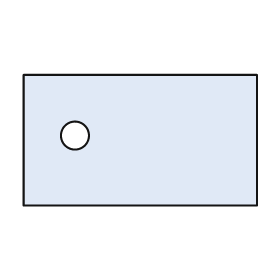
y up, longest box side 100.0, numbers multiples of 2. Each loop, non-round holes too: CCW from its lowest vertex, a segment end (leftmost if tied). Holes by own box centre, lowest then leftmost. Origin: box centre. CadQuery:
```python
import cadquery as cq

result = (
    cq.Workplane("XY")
    .moveTo(-50.0, -28.0)
    .lineTo(50.0, -28.0)
    .lineTo(50.0, 28.0)
    .lineTo(-50.0, 28.0)
    .close()
    .moveTo(-28.0, 2.0)
    .circle(6.0)
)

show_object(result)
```